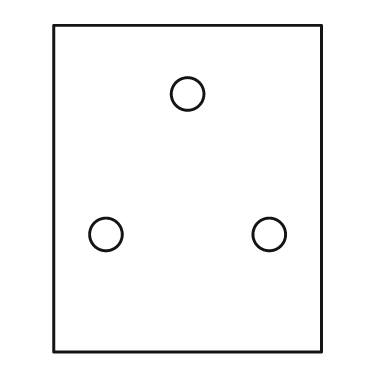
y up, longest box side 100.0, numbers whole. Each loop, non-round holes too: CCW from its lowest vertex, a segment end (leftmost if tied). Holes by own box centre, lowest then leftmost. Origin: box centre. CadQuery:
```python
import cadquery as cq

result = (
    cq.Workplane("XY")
    .moveTo(-41.0, -50.0)
    .lineTo(41.0, -50.0)
    .lineTo(41.0, 50.0)
    .lineTo(-41.0, 50.0)
    .close()
    .moveTo(-25.0, -14.0)
    .circle(5.0)
    .moveTo(25.0, -14.0)
    .circle(5.0)
    .moveTo(0.0, 29.0)
    .circle(5.0)
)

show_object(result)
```